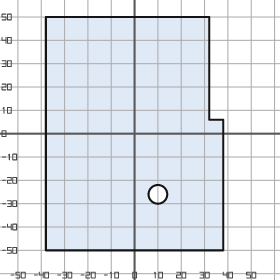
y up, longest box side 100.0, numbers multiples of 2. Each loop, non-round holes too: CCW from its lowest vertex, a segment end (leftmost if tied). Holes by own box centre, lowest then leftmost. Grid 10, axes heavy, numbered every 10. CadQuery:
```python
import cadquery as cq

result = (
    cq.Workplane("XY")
    .moveTo(-38.0, -50.0)
    .lineTo(38.0, -50.0)
    .lineTo(38.0, 6.0)
    .lineTo(32.0, 6.0)
    .lineTo(32.0, 50.0)
    .lineTo(-38.0, 50.0)
    .close()
    .moveTo(10.0, -26.0)
    .circle(4.0)
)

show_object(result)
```